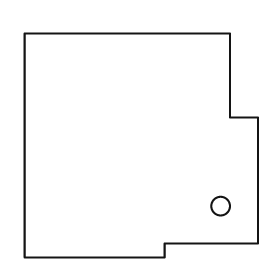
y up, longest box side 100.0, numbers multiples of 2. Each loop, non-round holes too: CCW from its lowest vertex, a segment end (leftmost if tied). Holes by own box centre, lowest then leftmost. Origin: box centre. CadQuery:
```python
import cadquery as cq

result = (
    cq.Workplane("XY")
    .moveTo(-50.0, -48.0)
    .lineTo(10.0, -48.0)
    .lineTo(10.0, -42.0)
    .lineTo(50.0, -42.0)
    .lineTo(50.0, 12.0)
    .lineTo(38.0, 12.0)
    .lineTo(38.0, 48.0)
    .lineTo(-50.0, 48.0)
    .close()
    .moveTo(34.0, -26.0)
    .circle(4.0)
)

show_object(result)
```